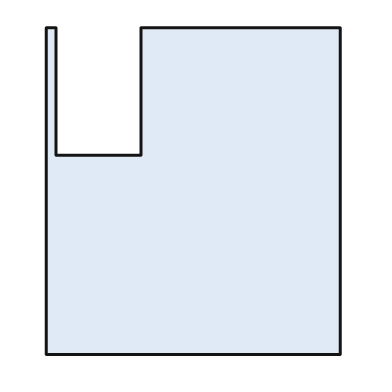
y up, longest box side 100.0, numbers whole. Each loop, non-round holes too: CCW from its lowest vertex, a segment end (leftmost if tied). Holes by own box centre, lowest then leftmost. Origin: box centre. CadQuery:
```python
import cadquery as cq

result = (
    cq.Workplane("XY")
    .moveTo(-45.0, -50.0)
    .lineTo(45.0, -50.0)
    .lineTo(45.0, 50.0)
    .lineTo(-16.0, 50.0)
    .lineTo(-16.0, 11.0)
    .lineTo(-42.0, 11.0)
    .lineTo(-42.0, 50.0)
    .lineTo(-45.0, 50.0)
    .close()
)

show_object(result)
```